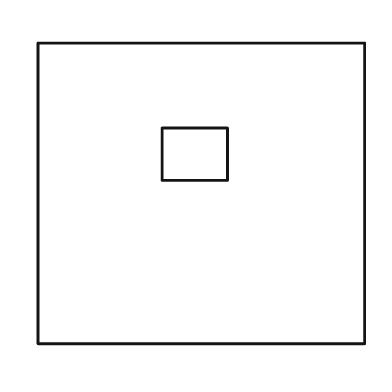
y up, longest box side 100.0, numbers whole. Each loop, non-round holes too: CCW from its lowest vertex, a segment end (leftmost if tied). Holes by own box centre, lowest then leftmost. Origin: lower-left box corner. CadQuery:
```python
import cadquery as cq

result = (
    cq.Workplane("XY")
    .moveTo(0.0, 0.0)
    .lineTo(100.0, 0.0)
    .lineTo(100.0, 92.0)
    .lineTo(0.0, 92.0)
    .close()
    .moveTo(38.0, 50.0)
    .lineTo(58.0, 50.0)
    .lineTo(58.0, 66.0)
    .lineTo(38.0, 66.0)
    .close()
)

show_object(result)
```